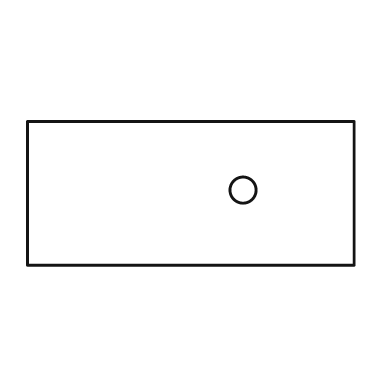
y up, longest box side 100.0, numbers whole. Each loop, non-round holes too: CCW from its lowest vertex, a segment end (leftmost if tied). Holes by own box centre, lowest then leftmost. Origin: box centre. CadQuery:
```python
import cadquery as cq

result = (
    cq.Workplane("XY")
    .moveTo(-50.0, -22.0)
    .lineTo(50.0, -22.0)
    .lineTo(50.0, 22.0)
    .lineTo(-50.0, 22.0)
    .close()
    .moveTo(16.0, 1.0)
    .circle(4.0)
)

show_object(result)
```